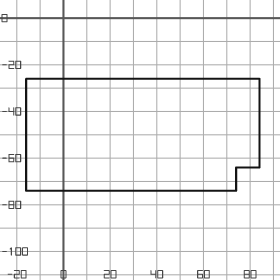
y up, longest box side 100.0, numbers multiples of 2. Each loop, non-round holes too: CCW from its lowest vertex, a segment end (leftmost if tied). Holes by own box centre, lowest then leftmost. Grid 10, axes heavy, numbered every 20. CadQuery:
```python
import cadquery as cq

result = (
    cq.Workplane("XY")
    .moveTo(-16.0, -74.0)
    .lineTo(74.0, -74.0)
    .lineTo(74.0, -64.0)
    .lineTo(84.0, -64.0)
    .lineTo(84.0, -26.0)
    .lineTo(-16.0, -26.0)
    .close()
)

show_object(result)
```